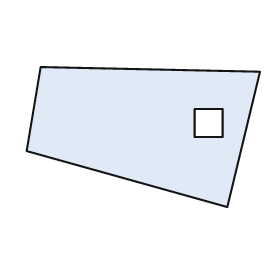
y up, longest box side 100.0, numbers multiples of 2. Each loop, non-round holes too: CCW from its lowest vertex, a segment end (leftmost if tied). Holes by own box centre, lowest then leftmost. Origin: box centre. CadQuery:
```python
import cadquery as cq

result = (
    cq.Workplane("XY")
    .moveTo(36.0, -30.0)
    .lineTo(50.0, 28.0)
    .lineTo(-44.0, 30.0)
    .lineTo(-50.0, -6.0)
    .close()
    .moveTo(22.0, 0.0)
    .lineTo(34.0, 0.0)
    .lineTo(34.0, 12.0)
    .lineTo(22.0, 12.0)
    .close()
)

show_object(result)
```